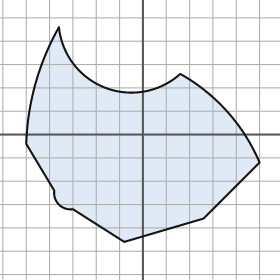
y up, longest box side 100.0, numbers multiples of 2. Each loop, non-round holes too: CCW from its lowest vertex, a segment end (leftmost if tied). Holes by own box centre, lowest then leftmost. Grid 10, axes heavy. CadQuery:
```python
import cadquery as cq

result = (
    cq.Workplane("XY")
    .moveTo(-8.0, -46.0)
    .lineTo(26.0, -36.0)
    .lineTo(50.0, -12.0)
    .threePointArc((36.0, 10.0), (16.0, 26.0))
    .threePointArc((-16.0, 20.0), (-36.0, 46.0))
    .threePointArc((-46.0, 22.0), (-50.0, -4.0))
    .lineTo(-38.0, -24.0)
    .threePointArc((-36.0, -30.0), (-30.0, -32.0))
    .close()
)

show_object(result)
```